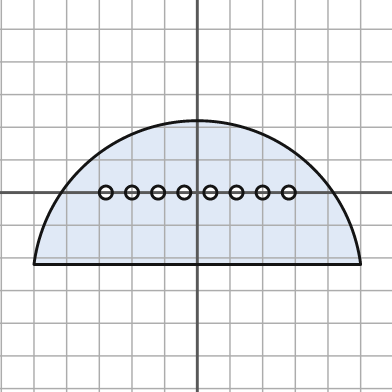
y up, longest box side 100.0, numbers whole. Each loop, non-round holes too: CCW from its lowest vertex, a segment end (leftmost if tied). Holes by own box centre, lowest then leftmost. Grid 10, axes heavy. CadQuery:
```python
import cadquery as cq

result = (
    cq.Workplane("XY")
    .moveTo(-50.0, -22.0)
    .lineTo(50.0, -22.0)
    .threePointArc((0.0, 22.0), (-50.0, -22.0))
    .close()
    .moveTo(-28.0, 0.0)
    .circle(2.0)
    .moveTo(-20.0, 0.0)
    .circle(2.0)
    .moveTo(-12.0, 0.0)
    .circle(2.0)
    .moveTo(-4.0, 0.0)
    .circle(2.0)
    .moveTo(4.0, 0.0)
    .circle(2.0)
    .moveTo(12.0, 0.0)
    .circle(2.0)
    .moveTo(20.0, 0.0)
    .circle(2.0)
    .moveTo(28.0, 0.0)
    .circle(2.0)
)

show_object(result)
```